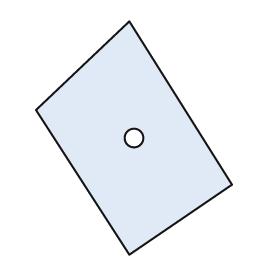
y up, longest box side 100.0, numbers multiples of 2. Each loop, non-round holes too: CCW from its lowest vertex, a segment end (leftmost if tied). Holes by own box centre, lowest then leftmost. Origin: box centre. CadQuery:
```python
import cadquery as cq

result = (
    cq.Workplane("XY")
    .moveTo(-2.0, -50.0)
    .lineTo(42.0, -20.0)
    .lineTo(-2.0, 50.0)
    .lineTo(-42.0, 12.0)
    .close()
    .moveTo(0.0, 0.0)
    .circle(4.0)
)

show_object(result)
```